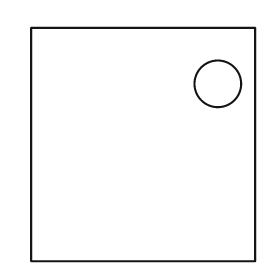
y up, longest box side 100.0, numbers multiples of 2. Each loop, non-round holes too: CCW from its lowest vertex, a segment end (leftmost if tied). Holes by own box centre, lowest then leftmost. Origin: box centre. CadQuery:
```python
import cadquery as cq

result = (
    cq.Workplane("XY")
    .moveTo(-48.0, -50.0)
    .lineTo(48.0, -50.0)
    .lineTo(48.0, 50.0)
    .lineTo(-48.0, 50.0)
    .close()
    .moveTo(32.0, 26.0)
    .circle(10.0)
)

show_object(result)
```